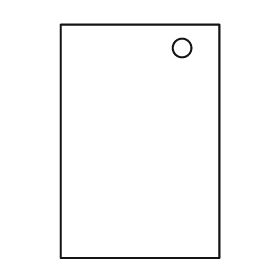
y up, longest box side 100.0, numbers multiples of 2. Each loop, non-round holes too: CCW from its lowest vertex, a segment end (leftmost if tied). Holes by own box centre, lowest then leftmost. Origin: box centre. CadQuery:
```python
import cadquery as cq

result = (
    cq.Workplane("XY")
    .moveTo(-34.0, -50.0)
    .lineTo(34.0, -50.0)
    .lineTo(34.0, 50.0)
    .lineTo(-34.0, 50.0)
    .close()
    .moveTo(18.0, 40.0)
    .circle(4.0)
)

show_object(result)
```